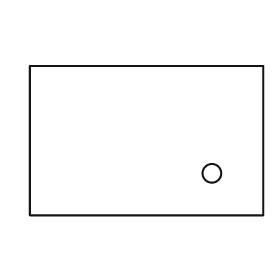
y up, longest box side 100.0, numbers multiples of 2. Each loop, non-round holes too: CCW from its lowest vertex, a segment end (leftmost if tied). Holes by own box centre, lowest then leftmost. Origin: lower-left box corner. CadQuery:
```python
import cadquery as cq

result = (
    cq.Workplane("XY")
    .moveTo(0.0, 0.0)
    .lineTo(100.0, 0.0)
    .lineTo(100.0, 64.0)
    .lineTo(0.0, 64.0)
    .close()
    .moveTo(78.0, 18.0)
    .circle(4.0)
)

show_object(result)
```